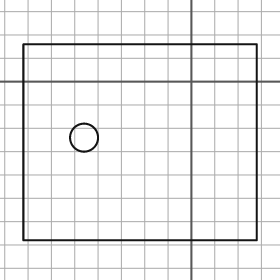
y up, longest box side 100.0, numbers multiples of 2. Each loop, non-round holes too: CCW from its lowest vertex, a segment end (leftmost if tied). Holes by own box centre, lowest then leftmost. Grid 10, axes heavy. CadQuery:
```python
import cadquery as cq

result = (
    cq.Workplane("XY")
    .moveTo(-72.0, -68.0)
    .lineTo(28.0, -68.0)
    .lineTo(28.0, 16.0)
    .lineTo(-72.0, 16.0)
    .close()
    .moveTo(-46.0, -24.0)
    .circle(6.0)
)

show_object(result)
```